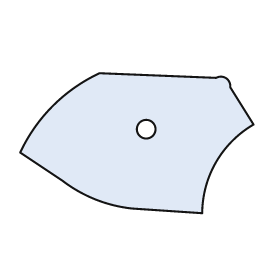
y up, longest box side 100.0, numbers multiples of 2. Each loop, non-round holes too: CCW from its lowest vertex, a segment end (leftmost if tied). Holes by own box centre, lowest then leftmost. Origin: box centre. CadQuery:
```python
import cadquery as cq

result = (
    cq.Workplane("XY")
    .moveTo(28.0, -30.0)
    .threePointArc((34.0, -8.0), (50.0, 8.0))
    .lineTo(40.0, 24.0)
    .threePointArc((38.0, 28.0), (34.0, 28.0))
    .lineTo(-16.0, 30.0)
    .threePointArc((-36.0, 16.0), (-50.0, -4.0))
    .lineTo(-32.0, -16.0)
    .threePointArc((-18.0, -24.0), (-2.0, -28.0))
    .close()
    .moveTo(4.0, 6.0)
    .circle(4.0)
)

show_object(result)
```